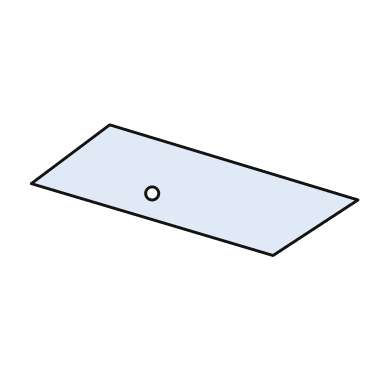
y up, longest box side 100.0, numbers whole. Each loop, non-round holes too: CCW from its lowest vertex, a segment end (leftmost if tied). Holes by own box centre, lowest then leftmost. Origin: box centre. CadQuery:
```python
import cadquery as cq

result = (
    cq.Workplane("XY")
    .moveTo(24.0, -20.0)
    .lineTo(50.0, -3.0)
    .lineTo(-26.0, 20.0)
    .lineTo(-50.0, 2.0)
    .close()
    .moveTo(-13.0, -1.0)
    .circle(2.0)
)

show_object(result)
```